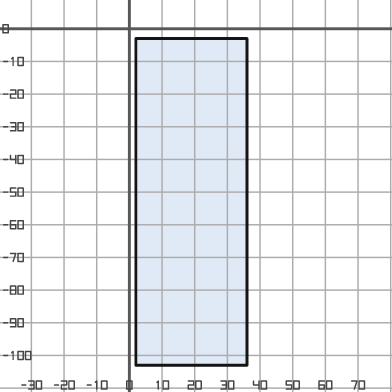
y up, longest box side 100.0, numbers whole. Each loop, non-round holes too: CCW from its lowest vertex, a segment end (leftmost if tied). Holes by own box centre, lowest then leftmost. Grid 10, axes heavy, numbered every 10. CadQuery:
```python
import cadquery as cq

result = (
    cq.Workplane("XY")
    .moveTo(2.0, -103.0)
    .lineTo(36.0, -103.0)
    .lineTo(36.0, -3.0)
    .lineTo(2.0, -3.0)
    .close()
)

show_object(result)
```